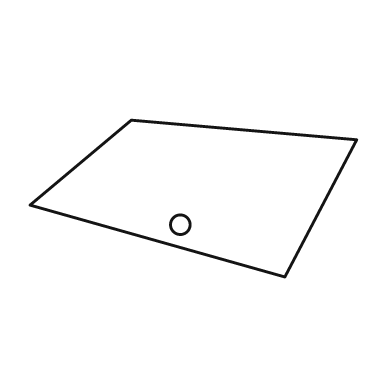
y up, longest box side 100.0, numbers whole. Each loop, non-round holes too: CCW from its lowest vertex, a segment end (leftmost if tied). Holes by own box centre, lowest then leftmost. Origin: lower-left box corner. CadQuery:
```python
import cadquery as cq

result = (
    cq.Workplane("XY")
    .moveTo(78.0, 0.0)
    .lineTo(100.0, 42.0)
    .lineTo(31.0, 48.0)
    .lineTo(0.0, 22.0)
    .close()
    .moveTo(46.0, 16.0)
    .circle(3.0)
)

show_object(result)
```